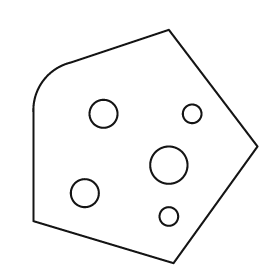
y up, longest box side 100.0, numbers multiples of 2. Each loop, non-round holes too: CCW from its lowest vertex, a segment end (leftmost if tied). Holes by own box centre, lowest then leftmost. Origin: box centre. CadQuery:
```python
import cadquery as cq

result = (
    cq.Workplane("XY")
    .moveTo(12.0, -50.0)
    .lineTo(48.0, 0.0)
    .lineTo(10.0, 50.0)
    .lineTo(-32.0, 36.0)
    .threePointArc((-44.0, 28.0), (-48.0, 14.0))
    .lineTo(-48.0, -32.0)
    .close()
    .moveTo(10.0, -30.0)
    .circle(4.0)
    .moveTo(-26.0, -20.0)
    .circle(6.0)
    .moveTo(10.0, -8.0)
    .circle(8.0)
    .moveTo(-18.0, 14.0)
    .circle(6.0)
    .moveTo(20.0, 14.0)
    .circle(4.0)
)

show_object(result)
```